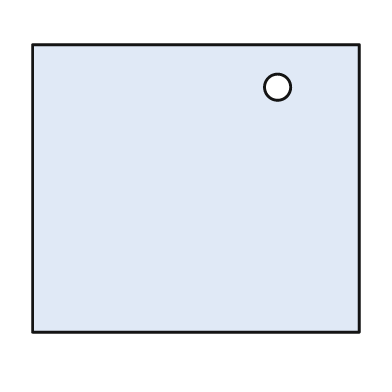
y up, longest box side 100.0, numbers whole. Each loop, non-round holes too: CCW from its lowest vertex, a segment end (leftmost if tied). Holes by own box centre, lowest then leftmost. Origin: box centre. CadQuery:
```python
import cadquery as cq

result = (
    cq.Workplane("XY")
    .moveTo(-50.0, -44.0)
    .lineTo(50.0, -44.0)
    .lineTo(50.0, 44.0)
    .lineTo(-50.0, 44.0)
    .close()
    .moveTo(25.0, 31.0)
    .circle(4.0)
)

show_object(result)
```